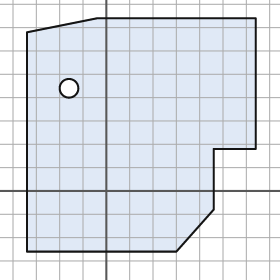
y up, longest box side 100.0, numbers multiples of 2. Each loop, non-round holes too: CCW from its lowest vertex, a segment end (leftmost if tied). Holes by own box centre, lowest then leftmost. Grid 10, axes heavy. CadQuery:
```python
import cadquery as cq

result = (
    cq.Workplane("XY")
    .moveTo(-34.0, -26.0)
    .lineTo(30.0, -26.0)
    .lineTo(46.0, -8.0)
    .lineTo(46.0, 18.0)
    .lineTo(64.0, 18.0)
    .lineTo(64.0, 74.0)
    .lineTo(-4.0, 74.0)
    .lineTo(-34.0, 68.0)
    .close()
    .moveTo(-16.0, 44.0)
    .circle(4.0)
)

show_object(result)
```